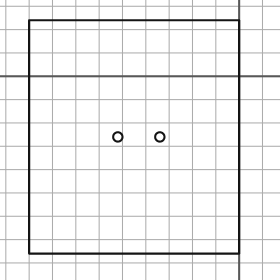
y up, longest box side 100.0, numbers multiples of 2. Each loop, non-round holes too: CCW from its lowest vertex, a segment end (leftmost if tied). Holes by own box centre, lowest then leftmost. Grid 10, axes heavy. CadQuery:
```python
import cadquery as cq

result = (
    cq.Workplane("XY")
    .moveTo(-90.0, -76.0)
    .lineTo(0.0, -76.0)
    .lineTo(0.0, 24.0)
    .lineTo(-90.0, 24.0)
    .close()
    .moveTo(-52.0, -26.0)
    .circle(2.0)
    .moveTo(-34.0, -26.0)
    .circle(2.0)
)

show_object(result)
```